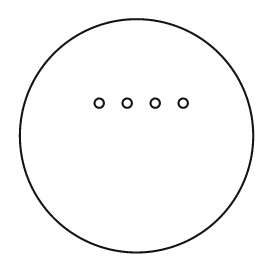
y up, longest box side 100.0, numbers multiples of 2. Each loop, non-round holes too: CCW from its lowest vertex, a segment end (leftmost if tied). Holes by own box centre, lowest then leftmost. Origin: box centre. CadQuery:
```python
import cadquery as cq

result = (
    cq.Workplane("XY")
    .moveTo(0.0, 0.0)
    .circle(50.0)
    .moveTo(-16.0, 14.0)
    .circle(2.0)
    .moveTo(-4.0, 14.0)
    .circle(2.0)
    .moveTo(8.0, 14.0)
    .circle(2.0)
    .moveTo(20.0, 14.0)
    .circle(2.0)
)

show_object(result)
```